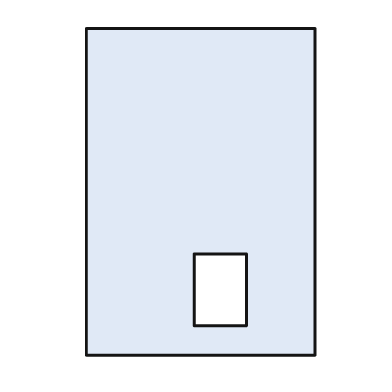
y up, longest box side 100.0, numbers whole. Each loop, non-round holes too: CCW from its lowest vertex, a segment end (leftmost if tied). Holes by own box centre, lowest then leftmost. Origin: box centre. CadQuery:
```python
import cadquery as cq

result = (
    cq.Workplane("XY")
    .moveTo(-35.0, -50.0)
    .lineTo(35.0, -50.0)
    .lineTo(35.0, 50.0)
    .lineTo(-35.0, 50.0)
    .close()
    .moveTo(-2.0, -41.0)
    .lineTo(14.0, -41.0)
    .lineTo(14.0, -19.0)
    .lineTo(-2.0, -19.0)
    .close()
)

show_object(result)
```